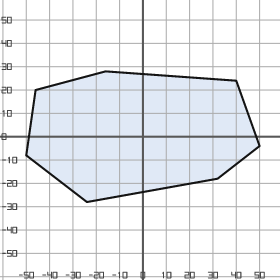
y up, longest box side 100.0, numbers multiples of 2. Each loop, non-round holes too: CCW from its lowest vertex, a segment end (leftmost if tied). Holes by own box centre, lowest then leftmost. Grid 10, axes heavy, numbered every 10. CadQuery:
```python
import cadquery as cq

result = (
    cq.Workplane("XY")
    .moveTo(-24.0, -28.0)
    .lineTo(32.0, -18.0)
    .lineTo(50.0, -4.0)
    .lineTo(40.0, 24.0)
    .lineTo(-16.0, 28.0)
    .lineTo(-46.0, 20.0)
    .lineTo(-50.0, -8.0)
    .close()
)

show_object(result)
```